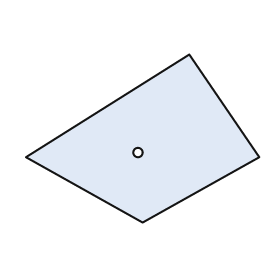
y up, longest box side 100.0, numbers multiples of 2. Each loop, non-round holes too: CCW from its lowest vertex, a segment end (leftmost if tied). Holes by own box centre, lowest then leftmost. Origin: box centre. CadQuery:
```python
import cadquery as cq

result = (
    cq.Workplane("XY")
    .moveTo(0.0, -36.0)
    .lineTo(50.0, -8.0)
    .lineTo(20.0, 36.0)
    .lineTo(-50.0, -8.0)
    .close()
    .moveTo(-2.0, -6.0)
    .circle(2.0)
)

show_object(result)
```